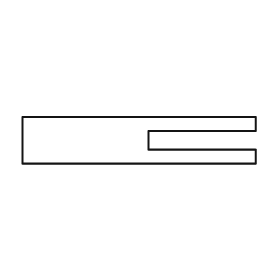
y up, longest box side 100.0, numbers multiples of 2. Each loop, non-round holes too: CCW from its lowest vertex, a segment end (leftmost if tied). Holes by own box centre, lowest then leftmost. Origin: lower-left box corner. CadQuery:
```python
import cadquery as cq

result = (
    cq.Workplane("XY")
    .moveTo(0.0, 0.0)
    .lineTo(100.0, 0.0)
    .lineTo(100.0, 6.0)
    .lineTo(54.0, 6.0)
    .lineTo(54.0, 14.0)
    .lineTo(100.0, 14.0)
    .lineTo(100.0, 20.0)
    .lineTo(0.0, 20.0)
    .close()
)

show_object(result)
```